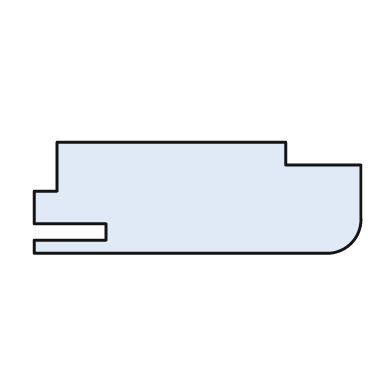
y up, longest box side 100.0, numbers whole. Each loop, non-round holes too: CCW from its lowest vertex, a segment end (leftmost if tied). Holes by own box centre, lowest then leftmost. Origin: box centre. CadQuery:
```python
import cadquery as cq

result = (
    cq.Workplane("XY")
    .moveTo(-50.0, -17.0)
    .lineTo(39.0, -17.0)
    .threePointArc((47.0, -14.0), (50.0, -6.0))
    .lineTo(50.0, 10.0)
    .lineTo(27.0, 10.0)
    .lineTo(27.0, 17.0)
    .lineTo(-43.0, 17.0)
    .lineTo(-43.0, 2.0)
    .lineTo(-50.0, 2.0)
    .lineTo(-50.0, -8.0)
    .lineTo(-28.0, -8.0)
    .lineTo(-28.0, -13.0)
    .lineTo(-50.0, -13.0)
    .close()
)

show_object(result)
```